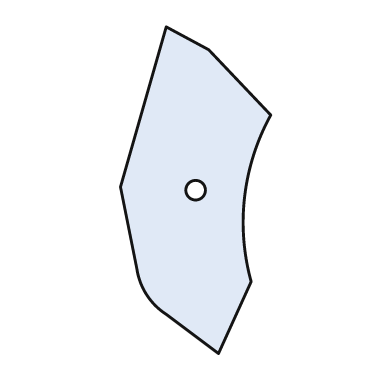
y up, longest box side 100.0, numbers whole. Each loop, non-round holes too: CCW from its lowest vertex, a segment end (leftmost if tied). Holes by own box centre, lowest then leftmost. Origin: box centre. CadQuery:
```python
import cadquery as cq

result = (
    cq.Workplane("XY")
    .moveTo(7.0, -50.0)
    .lineTo(17.0, -28.0)
    .threePointArc((15.0, -2.0), (23.0, 23.0))
    .lineTo(4.0, 43.0)
    .lineTo(-9.0, 50.0)
    .lineTo(-23.0, 1.0)
    .lineTo(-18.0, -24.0)
    .threePointArc((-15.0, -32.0), (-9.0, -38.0))
    .close()
    .moveTo(0.0, 0.0)
    .circle(3.0)
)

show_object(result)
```